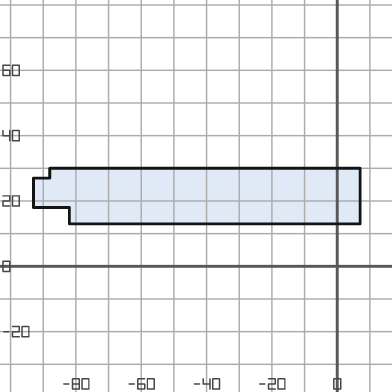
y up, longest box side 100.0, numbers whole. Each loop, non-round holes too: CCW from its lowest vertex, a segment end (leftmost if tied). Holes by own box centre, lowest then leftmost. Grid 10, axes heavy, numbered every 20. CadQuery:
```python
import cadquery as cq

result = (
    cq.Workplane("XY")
    .moveTo(-82.0, 13.0)
    .lineTo(7.0, 13.0)
    .lineTo(7.0, 30.0)
    .lineTo(-88.0, 30.0)
    .lineTo(-88.0, 27.0)
    .lineTo(-93.0, 27.0)
    .lineTo(-93.0, 18.0)
    .lineTo(-82.0, 18.0)
    .close()
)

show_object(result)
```